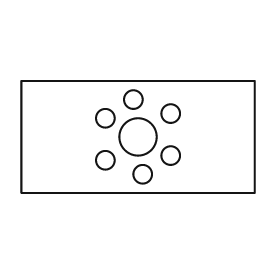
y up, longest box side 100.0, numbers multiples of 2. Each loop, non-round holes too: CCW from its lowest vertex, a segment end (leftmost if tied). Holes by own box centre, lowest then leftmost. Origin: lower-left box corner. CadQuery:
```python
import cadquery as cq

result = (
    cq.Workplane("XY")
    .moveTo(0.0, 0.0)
    .lineTo(100.0, 0.0)
    .lineTo(100.0, 48.0)
    .lineTo(0.0, 48.0)
    .close()
    .moveTo(52.0, 8.0)
    .circle(4.0)
    .moveTo(36.0, 14.0)
    .circle(4.0)
    .moveTo(64.0, 16.0)
    .circle(4.0)
    .moveTo(50.0, 24.0)
    .circle(8.0)
    .moveTo(36.0, 32.0)
    .circle(4.0)
    .moveTo(64.0, 34.0)
    .circle(4.0)
    .moveTo(48.0, 40.0)
    .circle(4.0)
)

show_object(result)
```